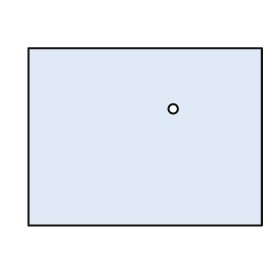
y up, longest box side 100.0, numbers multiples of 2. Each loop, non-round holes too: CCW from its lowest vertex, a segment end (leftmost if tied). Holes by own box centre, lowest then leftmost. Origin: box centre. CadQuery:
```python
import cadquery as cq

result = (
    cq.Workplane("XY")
    .moveTo(-50.0, -38.0)
    .lineTo(50.0, -38.0)
    .lineTo(50.0, 38.0)
    .lineTo(-50.0, 38.0)
    .close()
    .moveTo(12.0, 12.0)
    .circle(2.0)
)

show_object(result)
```